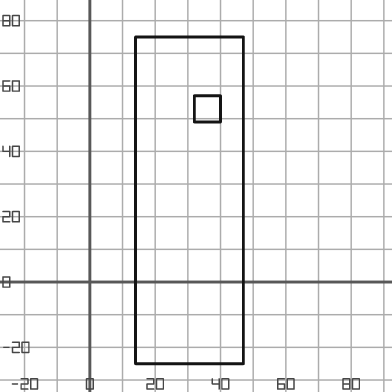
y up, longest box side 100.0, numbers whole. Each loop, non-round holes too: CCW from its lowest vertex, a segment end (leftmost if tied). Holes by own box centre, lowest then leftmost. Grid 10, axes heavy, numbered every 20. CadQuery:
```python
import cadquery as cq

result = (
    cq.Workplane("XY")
    .moveTo(14.0, -25.0)
    .lineTo(47.0, -25.0)
    .lineTo(47.0, 75.0)
    .lineTo(14.0, 75.0)
    .close()
    .moveTo(32.0, 49.0)
    .lineTo(40.0, 49.0)
    .lineTo(40.0, 57.0)
    .lineTo(32.0, 57.0)
    .close()
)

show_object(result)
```